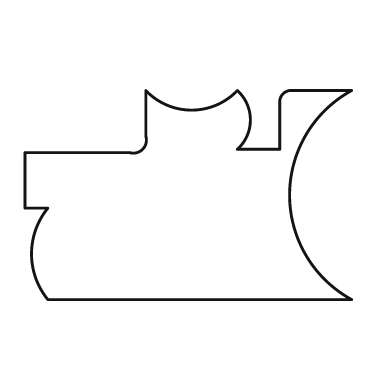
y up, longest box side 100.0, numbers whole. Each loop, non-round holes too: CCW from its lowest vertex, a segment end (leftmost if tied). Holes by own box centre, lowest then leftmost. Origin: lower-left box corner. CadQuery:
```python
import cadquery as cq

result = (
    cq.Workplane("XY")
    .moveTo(7.0, 0.0)
    .lineTo(100.0, 0.0)
    .threePointArc((81.0, 32.0), (100.0, 64.0))
    .lineTo(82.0, 64.0)
    .threePointArc((79.0, 63.0), (78.0, 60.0))
    .lineTo(78.0, 46.0)
    .lineTo(65.0, 46.0)
    .threePointArc((69.0, 55.0), (65.0, 64.0))
    .threePointArc((51.0, 58.0), (37.0, 64.0))
    .lineTo(37.0, 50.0)
    .threePointArc((36.0, 46.0), (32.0, 45.0))
    .lineTo(0.0, 45.0)
    .lineTo(0.0, 28.0)
    .lineTo(7.0, 28.0)
    .threePointArc((2.0, 14.0), (7.0, 0.0))
    .close()
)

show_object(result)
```